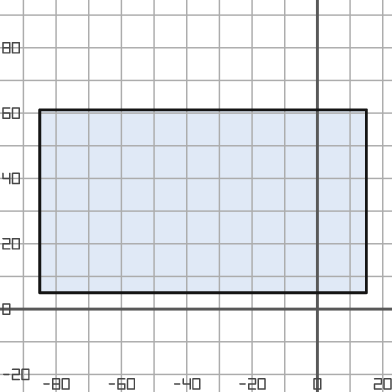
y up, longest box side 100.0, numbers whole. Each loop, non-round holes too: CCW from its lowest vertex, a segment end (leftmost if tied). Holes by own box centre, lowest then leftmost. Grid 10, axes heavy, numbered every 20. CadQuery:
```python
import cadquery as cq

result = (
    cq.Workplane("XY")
    .moveTo(-85.0, 5.0)
    .lineTo(15.0, 5.0)
    .lineTo(15.0, 61.0)
    .lineTo(-85.0, 61.0)
    .close()
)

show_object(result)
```